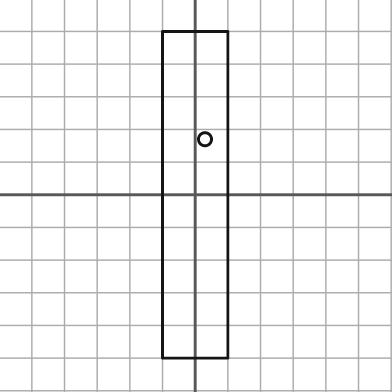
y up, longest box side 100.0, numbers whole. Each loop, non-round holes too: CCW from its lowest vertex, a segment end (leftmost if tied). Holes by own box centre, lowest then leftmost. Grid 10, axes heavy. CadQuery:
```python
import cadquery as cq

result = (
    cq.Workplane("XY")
    .moveTo(-10.0, -50.0)
    .lineTo(10.0, -50.0)
    .lineTo(10.0, 50.0)
    .lineTo(-10.0, 50.0)
    .close()
    .moveTo(3.0, 17.0)
    .circle(2.0)
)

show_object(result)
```